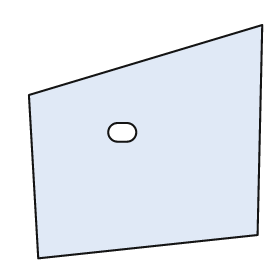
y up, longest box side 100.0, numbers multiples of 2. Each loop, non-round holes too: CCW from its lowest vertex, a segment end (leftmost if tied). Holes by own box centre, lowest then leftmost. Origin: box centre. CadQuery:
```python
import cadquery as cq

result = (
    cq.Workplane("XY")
    .moveTo(-46.0, -50.0)
    .lineTo(48.0, -40.0)
    .lineTo(50.0, 50.0)
    .lineTo(-50.0, 20.0)
    .close()
    .moveTo(-12.0, 0.0)
    .lineTo(-8.0, 0.0)
    .threePointArc((-4.0, 4.0), (-8.0, 8.0))
    .lineTo(-12.0, 8.0)
    .threePointArc((-16.0, 4.0), (-12.0, 0.0))
    .close()
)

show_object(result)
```